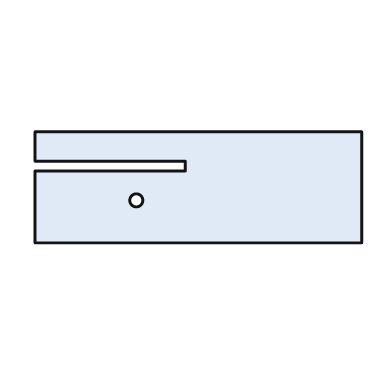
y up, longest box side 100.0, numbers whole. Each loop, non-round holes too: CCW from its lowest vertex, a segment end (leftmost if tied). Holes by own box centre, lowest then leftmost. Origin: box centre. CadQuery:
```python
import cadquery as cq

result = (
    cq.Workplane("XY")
    .moveTo(-50.0, -17.0)
    .lineTo(50.0, -17.0)
    .lineTo(50.0, 17.0)
    .lineTo(-50.0, 17.0)
    .lineTo(-50.0, 8.0)
    .lineTo(-4.0, 8.0)
    .lineTo(-4.0, 5.0)
    .lineTo(-50.0, 5.0)
    .close()
    .moveTo(-19.0, -4.0)
    .circle(2.0)
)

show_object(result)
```